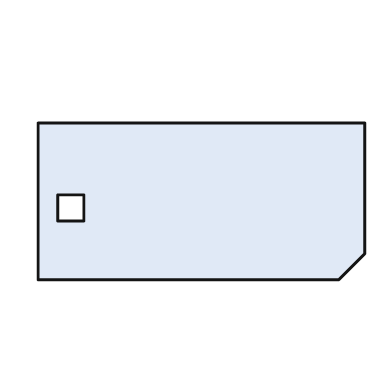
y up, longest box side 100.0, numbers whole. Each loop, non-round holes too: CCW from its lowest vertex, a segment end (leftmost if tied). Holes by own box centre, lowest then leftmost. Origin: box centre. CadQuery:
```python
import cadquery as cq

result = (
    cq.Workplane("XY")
    .moveTo(-50.0, -24.0)
    .lineTo(42.0, -24.0)
    .lineTo(50.0, -16.0)
    .lineTo(50.0, 24.0)
    .lineTo(-50.0, 24.0)
    .close()
    .moveTo(-44.0, -6.0)
    .lineTo(-36.0, -6.0)
    .lineTo(-36.0, 2.0)
    .lineTo(-44.0, 2.0)
    .close()
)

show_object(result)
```